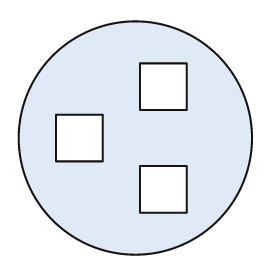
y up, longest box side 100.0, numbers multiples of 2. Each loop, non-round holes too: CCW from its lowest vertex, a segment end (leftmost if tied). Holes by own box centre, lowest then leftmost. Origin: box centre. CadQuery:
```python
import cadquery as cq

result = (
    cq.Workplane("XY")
    .moveTo(0.0, 0.0)
    .circle(50.0)
    .moveTo(2.0, -32.0)
    .lineTo(22.0, -32.0)
    .lineTo(22.0, -12.0)
    .lineTo(2.0, -12.0)
    .close()
    .moveTo(-34.0, -10.0)
    .lineTo(-14.0, -10.0)
    .lineTo(-14.0, 10.0)
    .lineTo(-34.0, 10.0)
    .close()
    .moveTo(2.0, 12.0)
    .lineTo(22.0, 12.0)
    .lineTo(22.0, 32.0)
    .lineTo(2.0, 32.0)
    .close()
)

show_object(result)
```